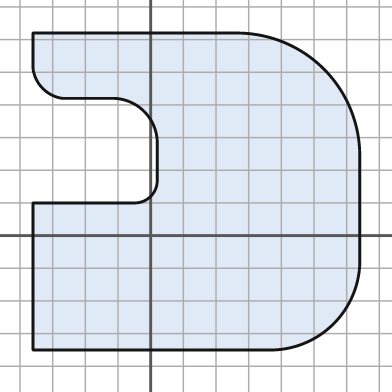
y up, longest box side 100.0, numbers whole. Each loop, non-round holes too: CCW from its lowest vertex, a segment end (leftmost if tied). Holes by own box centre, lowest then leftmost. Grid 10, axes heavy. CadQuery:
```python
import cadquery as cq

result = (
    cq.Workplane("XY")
    .moveTo(-36.0, -35.0)
    .lineTo(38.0, -35.0)
    .threePointArc((56.0, -27.0), (64.0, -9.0))
    .lineTo(64.0, 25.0)
    .threePointArc((53.0, 51.0), (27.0, 62.0))
    .lineTo(-36.0, 62.0)
    .lineTo(-36.0, 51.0)
    .threePointArc((-33.0, 45.0), (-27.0, 42.0))
    .lineTo(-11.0, 42.0)
    .threePointArc((-2.0, 38.0), (2.0, 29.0))
    .lineTo(2.0, 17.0)
    .threePointArc((0.0, 12.0), (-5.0, 10.0))
    .lineTo(-36.0, 10.0)
    .close()
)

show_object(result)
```